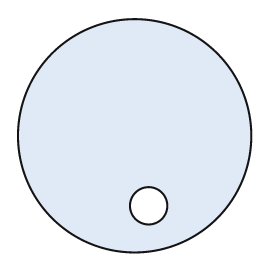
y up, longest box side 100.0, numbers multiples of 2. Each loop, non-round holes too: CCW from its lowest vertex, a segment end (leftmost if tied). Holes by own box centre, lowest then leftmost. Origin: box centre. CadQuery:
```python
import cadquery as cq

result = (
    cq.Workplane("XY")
    .moveTo(0.0, 0.0)
    .circle(50.0)
    .moveTo(6.0, -30.0)
    .circle(8.0)
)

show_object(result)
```